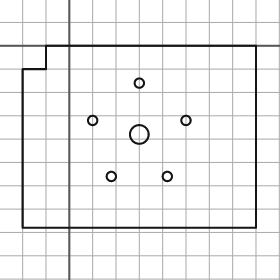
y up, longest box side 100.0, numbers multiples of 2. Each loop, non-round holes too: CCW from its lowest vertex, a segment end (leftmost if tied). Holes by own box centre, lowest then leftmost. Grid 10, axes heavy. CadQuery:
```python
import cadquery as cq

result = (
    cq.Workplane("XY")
    .moveTo(-20.0, -78.0)
    .lineTo(80.0, -78.0)
    .lineTo(80.0, 0.0)
    .lineTo(-10.0, 0.0)
    .lineTo(-10.0, -10.0)
    .lineTo(-20.0, -10.0)
    .close()
    .moveTo(18.0, -56.0)
    .circle(2.0)
    .moveTo(42.0, -56.0)
    .circle(2.0)
    .moveTo(30.0, -38.0)
    .circle(4.0)
    .moveTo(10.0, -32.0)
    .circle(2.0)
    .moveTo(50.0, -32.0)
    .circle(2.0)
    .moveTo(30.0, -16.0)
    .circle(2.0)
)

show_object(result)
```